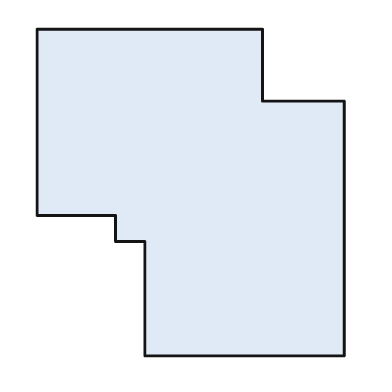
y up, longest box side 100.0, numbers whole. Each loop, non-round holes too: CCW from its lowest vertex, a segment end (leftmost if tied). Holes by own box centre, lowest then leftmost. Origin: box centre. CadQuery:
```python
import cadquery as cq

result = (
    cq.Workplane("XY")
    .moveTo(-14.0, -50.0)
    .lineTo(47.0, -50.0)
    .lineTo(47.0, 28.0)
    .lineTo(22.0, 28.0)
    .lineTo(22.0, 50.0)
    .lineTo(-47.0, 50.0)
    .lineTo(-47.0, -7.0)
    .lineTo(-23.0, -7.0)
    .lineTo(-23.0, -15.0)
    .lineTo(-14.0, -15.0)
    .close()
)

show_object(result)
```